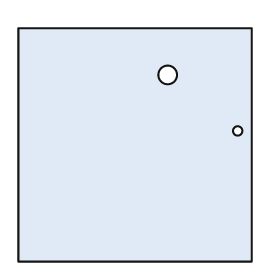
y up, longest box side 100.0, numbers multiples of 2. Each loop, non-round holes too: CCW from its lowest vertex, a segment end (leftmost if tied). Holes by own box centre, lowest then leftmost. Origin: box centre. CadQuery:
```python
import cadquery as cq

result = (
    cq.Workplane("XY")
    .moveTo(-50.0, -50.0)
    .lineTo(50.0, -50.0)
    .lineTo(50.0, 50.0)
    .lineTo(-50.0, 50.0)
    .close()
    .moveTo(44.0, 6.0)
    .circle(2.0)
    .moveTo(14.0, 30.0)
    .circle(4.0)
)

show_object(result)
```